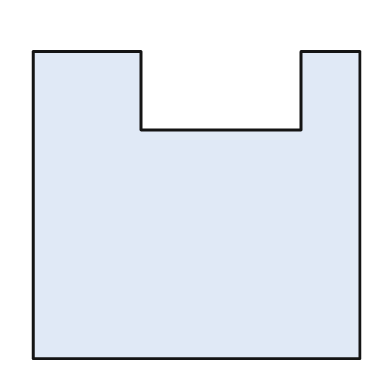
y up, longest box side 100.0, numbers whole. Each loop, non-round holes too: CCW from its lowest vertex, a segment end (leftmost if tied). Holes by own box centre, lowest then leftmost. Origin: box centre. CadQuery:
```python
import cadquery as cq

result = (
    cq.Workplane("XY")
    .moveTo(-50.0, -47.0)
    .lineTo(50.0, -47.0)
    .lineTo(50.0, 47.0)
    .lineTo(32.0, 47.0)
    .lineTo(32.0, 23.0)
    .lineTo(-17.0, 23.0)
    .lineTo(-17.0, 47.0)
    .lineTo(-50.0, 47.0)
    .close()
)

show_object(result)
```